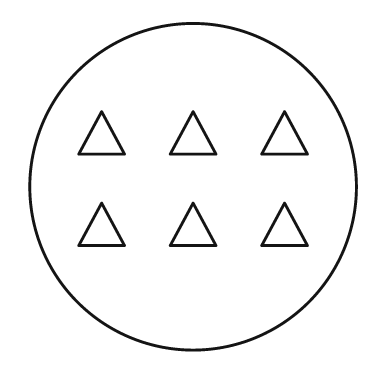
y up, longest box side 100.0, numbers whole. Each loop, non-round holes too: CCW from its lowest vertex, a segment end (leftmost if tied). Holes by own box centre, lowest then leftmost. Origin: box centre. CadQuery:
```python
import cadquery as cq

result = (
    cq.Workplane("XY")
    .moveTo(0.0, 0.0)
    .circle(50.0)
    .moveTo(-35.0, -18.0)
    .lineTo(-21.0, -18.0)
    .lineTo(-28.0, -5.0)
    .close()
    .moveTo(-7.0, -18.0)
    .lineTo(7.0, -18.0)
    .lineTo(0.0, -5.0)
    .close()
    .moveTo(21.0, -18.0)
    .lineTo(35.0, -18.0)
    .lineTo(28.0, -5.0)
    .close()
    .moveTo(-35.0, 10.0)
    .lineTo(-21.0, 10.0)
    .lineTo(-28.0, 23.0)
    .close()
    .moveTo(-7.0, 10.0)
    .lineTo(7.0, 10.0)
    .lineTo(0.0, 23.0)
    .close()
    .moveTo(21.0, 10.0)
    .lineTo(35.0, 10.0)
    .lineTo(28.0, 23.0)
    .close()
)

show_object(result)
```